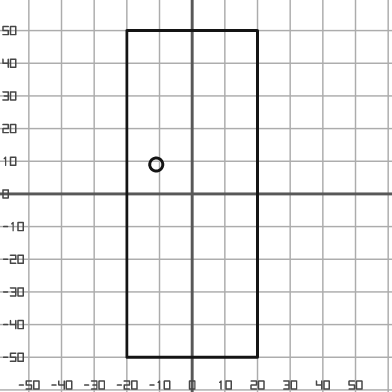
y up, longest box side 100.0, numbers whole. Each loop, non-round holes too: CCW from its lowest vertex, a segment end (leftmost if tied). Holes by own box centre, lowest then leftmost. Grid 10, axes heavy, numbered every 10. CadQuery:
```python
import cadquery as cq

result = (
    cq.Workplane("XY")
    .moveTo(-20.0, -50.0)
    .lineTo(20.0, -50.0)
    .lineTo(20.0, 50.0)
    .lineTo(-20.0, 50.0)
    .close()
    .moveTo(-11.0, 9.0)
    .circle(2.0)
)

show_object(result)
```